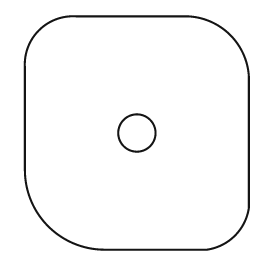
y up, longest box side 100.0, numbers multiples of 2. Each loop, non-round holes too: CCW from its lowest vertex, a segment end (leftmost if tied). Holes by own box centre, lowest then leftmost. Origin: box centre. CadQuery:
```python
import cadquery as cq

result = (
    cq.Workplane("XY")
    .moveTo(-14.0, -50.0)
    .lineTo(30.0, -50.0)
    .threePointArc((42.0, -44.0), (48.0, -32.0))
    .lineTo(48.0, 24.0)
    .threePointArc((40.0, 42.0), (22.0, 50.0))
    .lineTo(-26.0, 50.0)
    .threePointArc((-42.0, 44.0), (-48.0, 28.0))
    .lineTo(-48.0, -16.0)
    .threePointArc((-38.0, -40.0), (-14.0, -50.0))
    .close()
    .moveTo(0.0, 0.0)
    .circle(8.0)
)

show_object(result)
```